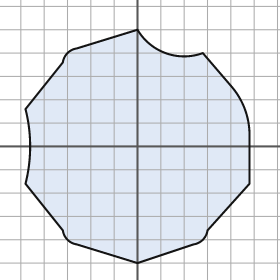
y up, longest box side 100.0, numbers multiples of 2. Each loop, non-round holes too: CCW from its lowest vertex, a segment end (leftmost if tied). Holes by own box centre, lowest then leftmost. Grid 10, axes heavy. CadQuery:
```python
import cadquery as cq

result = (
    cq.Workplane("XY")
    .moveTo(0.0, -50.0)
    .lineTo(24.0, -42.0)
    .threePointArc((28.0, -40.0), (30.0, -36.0))
    .lineTo(48.0, -16.0)
    .lineTo(48.0, 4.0)
    .threePointArc((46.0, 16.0), (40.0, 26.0))
    .lineTo(28.0, 40.0)
    .threePointArc((12.0, 40.0), (0.0, 50.0))
    .lineTo(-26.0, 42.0)
    .threePointArc((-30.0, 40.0), (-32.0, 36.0))
    .lineTo(-48.0, 16.0)
    .threePointArc((-46.0, 0.0), (-48.0, -16.0))
    .lineTo(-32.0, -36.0)
    .threePointArc((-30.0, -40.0), (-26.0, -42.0))
    .close()
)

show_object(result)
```